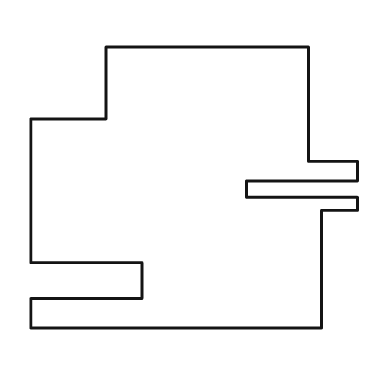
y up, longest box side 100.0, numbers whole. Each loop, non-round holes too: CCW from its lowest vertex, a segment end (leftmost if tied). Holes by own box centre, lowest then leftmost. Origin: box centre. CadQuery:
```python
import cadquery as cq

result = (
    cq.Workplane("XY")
    .moveTo(-50.0, -43.0)
    .lineTo(39.0, -43.0)
    .lineTo(39.0, -7.0)
    .lineTo(50.0, -7.0)
    .lineTo(50.0, -3.0)
    .lineTo(16.0, -3.0)
    .lineTo(16.0, 2.0)
    .lineTo(50.0, 2.0)
    .lineTo(50.0, 8.0)
    .lineTo(35.0, 8.0)
    .lineTo(35.0, 43.0)
    .lineTo(-27.0, 43.0)
    .lineTo(-27.0, 21.0)
    .lineTo(-50.0, 21.0)
    .lineTo(-50.0, -23.0)
    .lineTo(-16.0, -23.0)
    .lineTo(-16.0, -34.0)
    .lineTo(-50.0, -34.0)
    .close()
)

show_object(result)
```